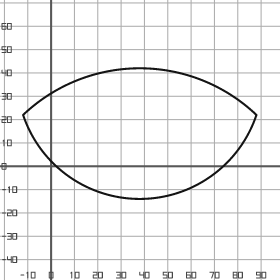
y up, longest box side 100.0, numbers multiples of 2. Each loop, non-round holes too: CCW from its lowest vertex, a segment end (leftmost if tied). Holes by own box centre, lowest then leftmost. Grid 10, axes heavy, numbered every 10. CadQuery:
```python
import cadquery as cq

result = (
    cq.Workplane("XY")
    .moveTo(-12.0, 22.0)
    .threePointArc((38.0, -14.0), (88.0, 22.0))
    .threePointArc((38.0, 42.0), (-12.0, 22.0))
    .close()
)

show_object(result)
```